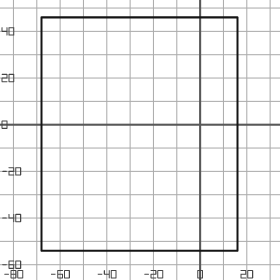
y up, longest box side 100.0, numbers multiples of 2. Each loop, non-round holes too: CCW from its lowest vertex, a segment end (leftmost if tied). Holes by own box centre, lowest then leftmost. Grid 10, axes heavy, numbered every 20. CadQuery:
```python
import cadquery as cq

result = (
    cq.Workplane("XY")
    .moveTo(-68.0, -54.0)
    .lineTo(16.0, -54.0)
    .lineTo(16.0, 46.0)
    .lineTo(-68.0, 46.0)
    .close()
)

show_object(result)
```